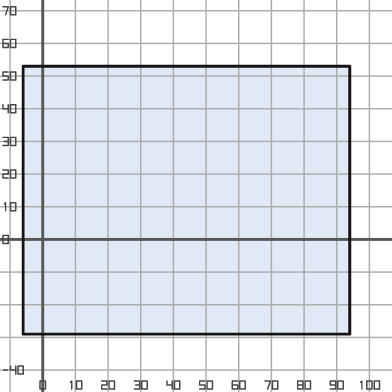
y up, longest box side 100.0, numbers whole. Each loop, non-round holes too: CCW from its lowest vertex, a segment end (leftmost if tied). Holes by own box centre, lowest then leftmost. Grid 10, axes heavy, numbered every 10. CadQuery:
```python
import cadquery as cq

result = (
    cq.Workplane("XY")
    .moveTo(-6.0, -29.0)
    .lineTo(94.0, -29.0)
    .lineTo(94.0, 53.0)
    .lineTo(-6.0, 53.0)
    .close()
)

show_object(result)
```